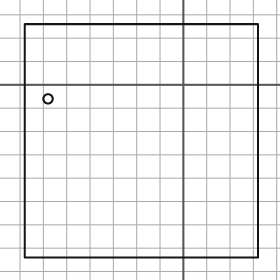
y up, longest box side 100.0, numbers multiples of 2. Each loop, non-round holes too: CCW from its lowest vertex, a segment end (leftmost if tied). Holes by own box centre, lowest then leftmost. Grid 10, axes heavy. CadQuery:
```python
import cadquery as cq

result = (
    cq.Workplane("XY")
    .moveTo(-68.0, -74.0)
    .lineTo(32.0, -74.0)
    .lineTo(32.0, 26.0)
    .lineTo(-68.0, 26.0)
    .close()
    .moveTo(-58.0, -6.0)
    .circle(2.0)
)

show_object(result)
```